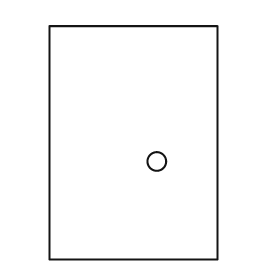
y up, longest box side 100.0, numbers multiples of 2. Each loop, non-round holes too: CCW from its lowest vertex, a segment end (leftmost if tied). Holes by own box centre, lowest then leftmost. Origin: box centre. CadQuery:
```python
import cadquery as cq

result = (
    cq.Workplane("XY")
    .moveTo(-36.0, -50.0)
    .lineTo(36.0, -50.0)
    .lineTo(36.0, 50.0)
    .lineTo(-36.0, 50.0)
    .close()
    .moveTo(10.0, -8.0)
    .circle(4.0)
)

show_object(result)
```